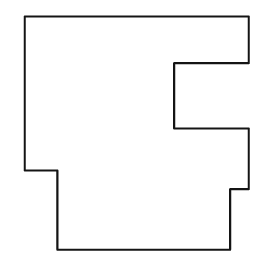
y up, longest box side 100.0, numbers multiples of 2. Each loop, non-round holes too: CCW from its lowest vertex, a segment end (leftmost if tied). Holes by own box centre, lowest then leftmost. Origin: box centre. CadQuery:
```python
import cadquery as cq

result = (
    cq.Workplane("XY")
    .moveTo(-34.0, -50.0)
    .lineTo(40.0, -50.0)
    .lineTo(40.0, -24.0)
    .lineTo(48.0, -24.0)
    .lineTo(48.0, 2.0)
    .lineTo(16.0, 2.0)
    .lineTo(16.0, 30.0)
    .lineTo(48.0, 30.0)
    .lineTo(48.0, 50.0)
    .lineTo(-48.0, 50.0)
    .lineTo(-48.0, -16.0)
    .lineTo(-34.0, -16.0)
    .close()
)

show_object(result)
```